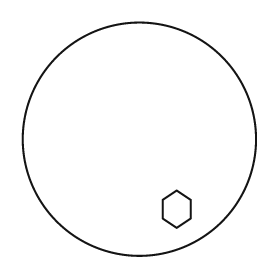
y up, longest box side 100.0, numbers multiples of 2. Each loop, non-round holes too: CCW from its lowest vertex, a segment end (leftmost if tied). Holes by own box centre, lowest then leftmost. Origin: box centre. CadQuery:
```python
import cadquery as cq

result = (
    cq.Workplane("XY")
    .moveTo(0.0, 0.0)
    .circle(50.0)
    .moveTo(16.0, -38.0)
    .lineTo(22.0, -34.0)
    .lineTo(22.0, -26.0)
    .lineTo(16.0, -22.0)
    .lineTo(10.0, -26.0)
    .lineTo(10.0, -34.0)
    .close()
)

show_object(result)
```